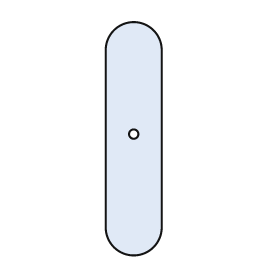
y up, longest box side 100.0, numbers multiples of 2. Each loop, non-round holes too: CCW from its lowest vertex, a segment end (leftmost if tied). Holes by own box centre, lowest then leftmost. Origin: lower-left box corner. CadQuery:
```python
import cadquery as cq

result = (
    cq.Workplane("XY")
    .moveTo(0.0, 12.0)
    .threePointArc((12.0, 0.0), (24.0, 12.0))
    .lineTo(24.0, 88.0)
    .threePointArc((12.0, 100.0), (0.0, 88.0))
    .close()
    .moveTo(12.0, 52.0)
    .circle(2.0)
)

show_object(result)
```